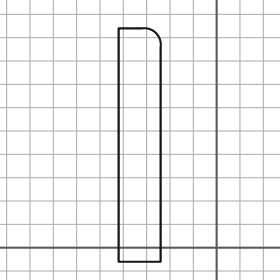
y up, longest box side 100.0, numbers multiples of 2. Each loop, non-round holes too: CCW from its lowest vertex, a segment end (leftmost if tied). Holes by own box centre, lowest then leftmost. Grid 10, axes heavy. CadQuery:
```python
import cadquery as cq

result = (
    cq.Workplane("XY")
    .moveTo(-42.0, -6.0)
    .lineTo(-24.0, -6.0)
    .lineTo(-24.0, 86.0)
    .threePointArc((-26.0, 92.0), (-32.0, 94.0))
    .lineTo(-42.0, 94.0)
    .close()
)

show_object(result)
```